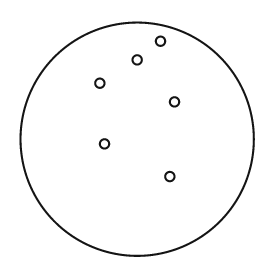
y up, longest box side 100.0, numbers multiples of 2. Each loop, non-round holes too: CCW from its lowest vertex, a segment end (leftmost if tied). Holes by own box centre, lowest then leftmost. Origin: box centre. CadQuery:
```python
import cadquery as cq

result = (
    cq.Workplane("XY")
    .moveTo(0.0, 0.0)
    .circle(50.0)
    .moveTo(14.0, -16.0)
    .circle(2.0)
    .moveTo(-14.0, -2.0)
    .circle(2.0)
    .moveTo(16.0, 16.0)
    .circle(2.0)
    .moveTo(-16.0, 24.0)
    .circle(2.0)
    .moveTo(0.0, 34.0)
    .circle(2.0)
    .moveTo(10.0, 42.0)
    .circle(2.0)
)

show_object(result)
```